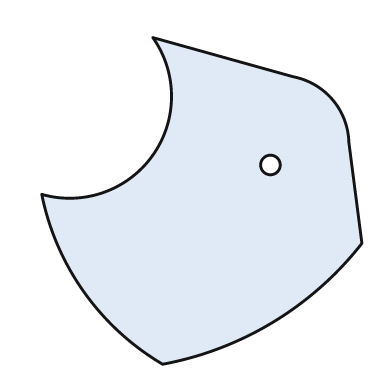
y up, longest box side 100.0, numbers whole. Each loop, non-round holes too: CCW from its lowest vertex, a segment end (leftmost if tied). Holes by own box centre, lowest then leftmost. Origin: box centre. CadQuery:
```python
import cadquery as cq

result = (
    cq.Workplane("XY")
    .moveTo(-12.0, -50.0)
    .threePointArc((22.0, -37.0), (49.0, -13.0))
    .lineTo(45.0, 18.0)
    .threePointArc((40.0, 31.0), (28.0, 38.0))
    .lineTo(-15.0, 50.0)
    .threePointArc((-15.0, 14.0), (-49.0, 2.0))
    .threePointArc((-36.0, -28.0), (-12.0, -50.0))
    .close()
    .moveTo(21.0, 11.0)
    .circle(3.0)
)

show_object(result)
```